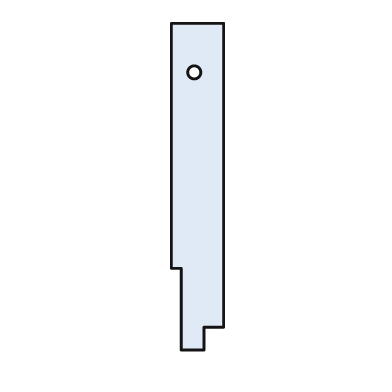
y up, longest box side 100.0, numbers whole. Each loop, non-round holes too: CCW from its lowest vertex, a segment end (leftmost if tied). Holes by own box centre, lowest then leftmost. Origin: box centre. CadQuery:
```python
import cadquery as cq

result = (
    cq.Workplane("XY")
    .moveTo(-5.0, -50.0)
    .lineTo(2.0, -50.0)
    .lineTo(2.0, -43.0)
    .lineTo(8.0, -43.0)
    .lineTo(8.0, 50.0)
    .lineTo(-8.0, 50.0)
    .lineTo(-8.0, -25.0)
    .lineTo(-5.0, -25.0)
    .close()
    .moveTo(-1.0, 35.0)
    .circle(2.0)
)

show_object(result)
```